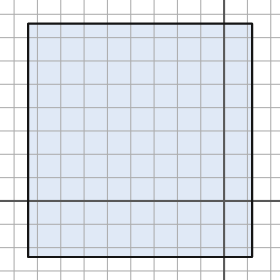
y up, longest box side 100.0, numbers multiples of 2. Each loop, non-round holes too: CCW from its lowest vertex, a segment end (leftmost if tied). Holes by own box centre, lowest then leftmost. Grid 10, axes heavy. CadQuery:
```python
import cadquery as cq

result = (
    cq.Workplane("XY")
    .moveTo(-84.0, -24.0)
    .lineTo(12.0, -24.0)
    .lineTo(12.0, 76.0)
    .lineTo(-84.0, 76.0)
    .close()
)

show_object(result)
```